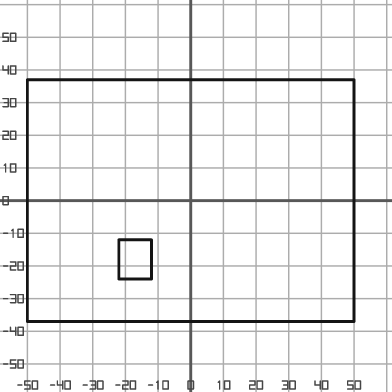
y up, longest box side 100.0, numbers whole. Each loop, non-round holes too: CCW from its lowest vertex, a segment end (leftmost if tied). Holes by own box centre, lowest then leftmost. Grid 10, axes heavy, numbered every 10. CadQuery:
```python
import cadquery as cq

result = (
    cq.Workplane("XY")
    .moveTo(-50.0, -37.0)
    .lineTo(50.0, -37.0)
    .lineTo(50.0, 37.0)
    .lineTo(-50.0, 37.0)
    .close()
    .moveTo(-22.0, -24.0)
    .lineTo(-12.0, -24.0)
    .lineTo(-12.0, -12.0)
    .lineTo(-22.0, -12.0)
    .close()
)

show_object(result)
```